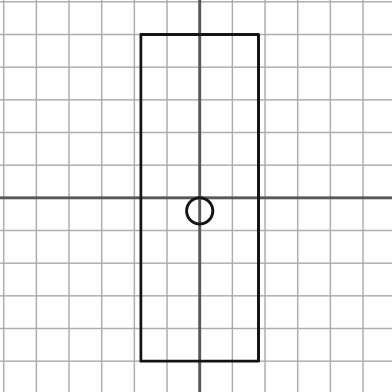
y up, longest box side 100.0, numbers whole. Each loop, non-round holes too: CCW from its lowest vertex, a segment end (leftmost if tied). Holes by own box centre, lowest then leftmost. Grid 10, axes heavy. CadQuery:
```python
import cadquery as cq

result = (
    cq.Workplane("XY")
    .moveTo(-18.0, -50.0)
    .lineTo(18.0, -50.0)
    .lineTo(18.0, 50.0)
    .lineTo(-18.0, 50.0)
    .close()
    .moveTo(0.0, -4.0)
    .circle(4.0)
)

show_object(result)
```